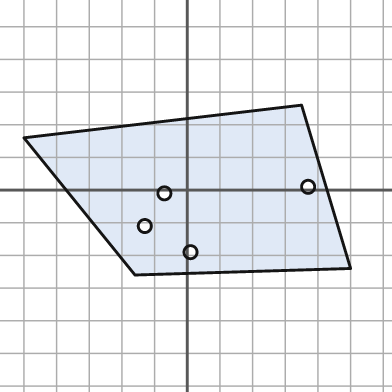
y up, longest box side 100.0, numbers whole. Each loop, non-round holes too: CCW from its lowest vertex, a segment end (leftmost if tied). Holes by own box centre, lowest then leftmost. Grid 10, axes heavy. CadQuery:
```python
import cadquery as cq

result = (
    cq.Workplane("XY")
    .moveTo(-16.0, -26.0)
    .lineTo(50.0, -24.0)
    .lineTo(35.0, 26.0)
    .lineTo(-50.0, 16.0)
    .close()
    .moveTo(1.0, -19.0)
    .circle(2.0)
    .moveTo(-13.0, -11.0)
    .circle(2.0)
    .moveTo(-7.0, -1.0)
    .circle(2.0)
    .moveTo(37.0, 1.0)
    .circle(2.0)
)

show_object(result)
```